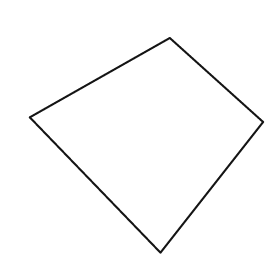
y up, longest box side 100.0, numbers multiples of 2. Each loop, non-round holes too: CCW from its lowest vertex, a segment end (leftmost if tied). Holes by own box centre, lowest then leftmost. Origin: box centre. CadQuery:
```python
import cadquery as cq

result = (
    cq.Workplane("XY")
    .moveTo(6.0, -46.0)
    .lineTo(50.0, 10.0)
    .lineTo(10.0, 46.0)
    .lineTo(-50.0, 12.0)
    .close()
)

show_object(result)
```